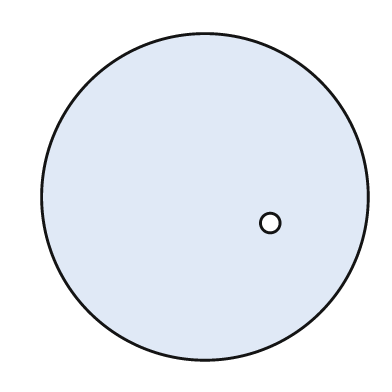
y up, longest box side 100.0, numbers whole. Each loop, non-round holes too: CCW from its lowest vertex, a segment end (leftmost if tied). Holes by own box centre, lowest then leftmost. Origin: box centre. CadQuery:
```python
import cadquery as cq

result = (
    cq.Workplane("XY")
    .moveTo(0.0, 0.0)
    .circle(50.0)
    .moveTo(20.0, -8.0)
    .circle(3.0)
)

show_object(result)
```